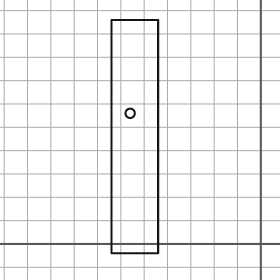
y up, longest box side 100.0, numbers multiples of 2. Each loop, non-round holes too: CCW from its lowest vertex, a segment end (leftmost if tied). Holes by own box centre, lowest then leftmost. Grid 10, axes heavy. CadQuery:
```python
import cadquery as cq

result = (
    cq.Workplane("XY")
    .moveTo(-64.0, -4.0)
    .lineTo(-44.0, -4.0)
    .lineTo(-44.0, 96.0)
    .lineTo(-64.0, 96.0)
    .close()
    .moveTo(-56.0, 56.0)
    .circle(2.0)
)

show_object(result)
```